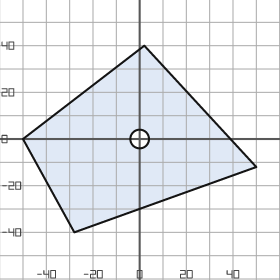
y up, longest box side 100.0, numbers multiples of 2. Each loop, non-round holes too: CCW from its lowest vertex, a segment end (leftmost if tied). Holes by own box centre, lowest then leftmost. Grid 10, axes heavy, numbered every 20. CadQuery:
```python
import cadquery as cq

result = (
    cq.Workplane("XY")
    .moveTo(-28.0, -40.0)
    .lineTo(50.0, -12.0)
    .lineTo(2.0, 40.0)
    .lineTo(-50.0, 0.0)
    .close()
    .moveTo(0.0, 0.0)
    .circle(4.0)
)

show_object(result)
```